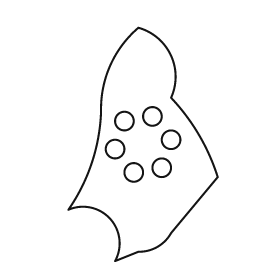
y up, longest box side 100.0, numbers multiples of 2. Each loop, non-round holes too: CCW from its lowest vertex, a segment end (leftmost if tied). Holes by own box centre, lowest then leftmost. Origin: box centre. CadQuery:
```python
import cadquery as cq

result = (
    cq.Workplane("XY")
    .moveTo(-12.0, -50.0)
    .lineTo(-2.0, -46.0)
    .threePointArc((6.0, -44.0), (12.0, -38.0))
    .lineTo(32.0, -14.0)
    .threePointArc((24.0, 4.0), (12.0, 20.0))
    .threePointArc((12.0, 38.0), (-2.0, 50.0))
    .threePointArc((-14.0, 34.0), (-18.0, 14.0))
    .threePointArc((-22.0, -8.0), (-32.0, -28.0))
    .threePointArc((-14.0, -32.0), (-12.0, -50.0))
    .close()
    .moveTo(-4.0, -12.0)
    .circle(4.0)
    .moveTo(8.0, -10.0)
    .circle(4.0)
    .moveTo(-12.0, -2.0)
    .circle(4.0)
    .moveTo(12.0, 2.0)
    .circle(4.0)
    .moveTo(-8.0, 10.0)
    .circle(4.0)
    .moveTo(4.0, 12.0)
    .circle(4.0)
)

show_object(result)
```